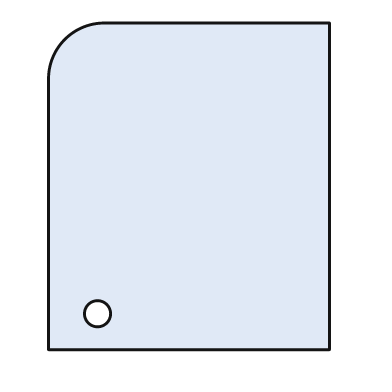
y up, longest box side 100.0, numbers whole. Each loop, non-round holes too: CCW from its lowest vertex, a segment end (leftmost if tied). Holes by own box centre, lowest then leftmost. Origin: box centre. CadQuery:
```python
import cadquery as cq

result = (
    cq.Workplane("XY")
    .moveTo(-43.0, -50.0)
    .lineTo(43.0, -50.0)
    .lineTo(43.0, 50.0)
    .lineTo(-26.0, 50.0)
    .threePointArc((-38.0, 45.0), (-43.0, 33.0))
    .close()
    .moveTo(-28.0, -39.0)
    .circle(4.0)
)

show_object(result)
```